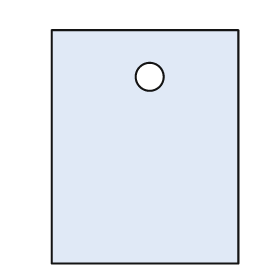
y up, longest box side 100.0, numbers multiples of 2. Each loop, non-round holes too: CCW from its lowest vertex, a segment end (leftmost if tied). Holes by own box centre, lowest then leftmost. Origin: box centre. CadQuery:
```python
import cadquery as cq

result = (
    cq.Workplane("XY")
    .moveTo(-40.0, -50.0)
    .lineTo(40.0, -50.0)
    .lineTo(40.0, 50.0)
    .lineTo(-40.0, 50.0)
    .close()
    .moveTo(2.0, 30.0)
    .circle(6.0)
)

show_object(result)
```